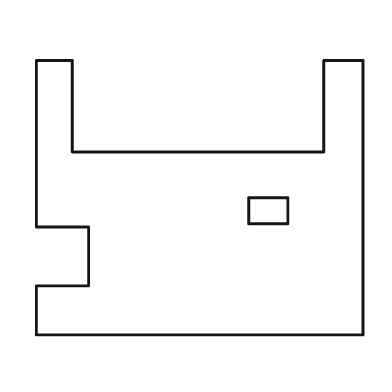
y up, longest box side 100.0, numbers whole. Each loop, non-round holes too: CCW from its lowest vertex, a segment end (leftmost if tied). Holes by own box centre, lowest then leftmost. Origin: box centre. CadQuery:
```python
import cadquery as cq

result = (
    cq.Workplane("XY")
    .moveTo(-50.0, -42.0)
    .lineTo(50.0, -42.0)
    .lineTo(50.0, 42.0)
    .lineTo(38.0, 42.0)
    .lineTo(38.0, 14.0)
    .lineTo(-39.0, 14.0)
    .lineTo(-39.0, 42.0)
    .lineTo(-50.0, 42.0)
    .lineTo(-50.0, -9.0)
    .lineTo(-34.0, -9.0)
    .lineTo(-34.0, -27.0)
    .lineTo(-50.0, -27.0)
    .close()
    .moveTo(15.0, -8.0)
    .lineTo(27.0, -8.0)
    .lineTo(27.0, 0.0)
    .lineTo(15.0, 0.0)
    .close()
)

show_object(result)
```